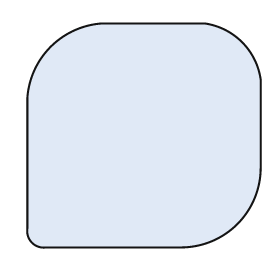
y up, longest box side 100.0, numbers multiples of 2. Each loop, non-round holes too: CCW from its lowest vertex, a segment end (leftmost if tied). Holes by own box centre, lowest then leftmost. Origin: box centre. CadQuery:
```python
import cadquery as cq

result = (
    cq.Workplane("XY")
    .moveTo(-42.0, -48.0)
    .lineTo(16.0, -48.0)
    .threePointArc((40.0, -38.0), (50.0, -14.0))
    .lineTo(50.0, 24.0)
    .threePointArc((42.0, 40.0), (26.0, 48.0))
    .lineTo(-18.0, 48.0)
    .threePointArc((-40.0, 38.0), (-50.0, 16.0))
    .lineTo(-50.0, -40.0)
    .threePointArc((-48.0, -46.0), (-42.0, -48.0))
    .close()
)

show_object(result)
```